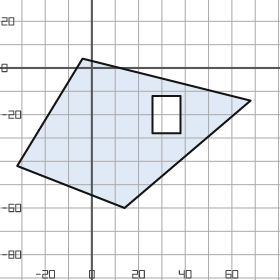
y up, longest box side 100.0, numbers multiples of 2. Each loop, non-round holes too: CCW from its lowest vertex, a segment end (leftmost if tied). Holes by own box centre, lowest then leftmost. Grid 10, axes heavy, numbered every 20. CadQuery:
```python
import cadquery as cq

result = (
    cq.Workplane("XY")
    .moveTo(14.0, -60.0)
    .lineTo(68.0, -14.0)
    .lineTo(-4.0, 4.0)
    .lineTo(-32.0, -42.0)
    .close()
    .moveTo(26.0, -28.0)
    .lineTo(38.0, -28.0)
    .lineTo(38.0, -12.0)
    .lineTo(26.0, -12.0)
    .close()
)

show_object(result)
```